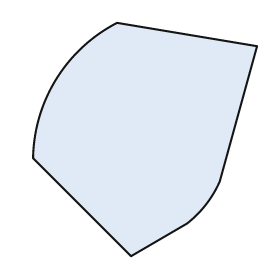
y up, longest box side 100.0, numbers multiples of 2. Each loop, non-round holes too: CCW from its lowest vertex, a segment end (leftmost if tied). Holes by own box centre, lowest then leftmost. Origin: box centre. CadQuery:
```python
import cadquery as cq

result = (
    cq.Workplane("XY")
    .moveTo(-6.0, -50.0)
    .lineTo(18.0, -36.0)
    .threePointArc((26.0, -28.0), (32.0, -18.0))
    .lineTo(48.0, 40.0)
    .lineTo(-12.0, 50.0)
    .threePointArc((-38.0, 26.0), (-48.0, -8.0))
    .close()
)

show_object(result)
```